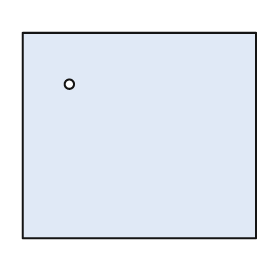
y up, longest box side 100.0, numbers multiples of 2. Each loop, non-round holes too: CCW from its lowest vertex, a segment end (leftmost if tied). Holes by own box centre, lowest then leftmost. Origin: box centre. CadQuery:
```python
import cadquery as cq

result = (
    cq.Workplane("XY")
    .moveTo(-50.0, -44.0)
    .lineTo(50.0, -44.0)
    .lineTo(50.0, 44.0)
    .lineTo(-50.0, 44.0)
    .close()
    .moveTo(-30.0, 22.0)
    .circle(2.0)
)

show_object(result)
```